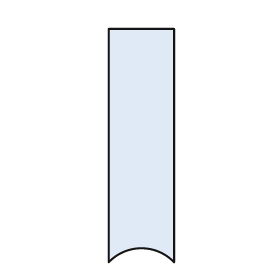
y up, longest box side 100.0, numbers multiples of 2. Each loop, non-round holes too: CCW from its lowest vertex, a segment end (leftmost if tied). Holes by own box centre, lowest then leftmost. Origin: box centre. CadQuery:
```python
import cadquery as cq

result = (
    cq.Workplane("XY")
    .moveTo(-14.0, -50.0)
    .threePointArc((0.0, -44.0), (14.0, -50.0))
    .lineTo(14.0, 50.0)
    .lineTo(-14.0, 50.0)
    .close()
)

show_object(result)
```